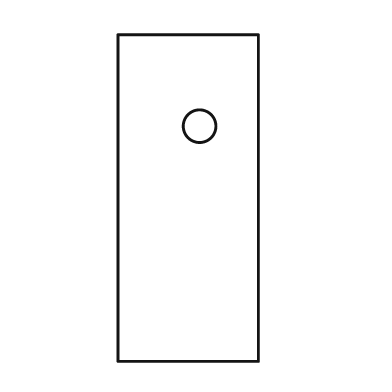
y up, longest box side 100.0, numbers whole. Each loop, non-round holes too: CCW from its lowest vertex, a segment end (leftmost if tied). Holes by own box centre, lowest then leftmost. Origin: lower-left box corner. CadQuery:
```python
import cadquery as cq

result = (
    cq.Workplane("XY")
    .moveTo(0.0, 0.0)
    .lineTo(43.0, 0.0)
    .lineTo(43.0, 100.0)
    .lineTo(0.0, 100.0)
    .close()
    .moveTo(25.0, 72.0)
    .circle(5.0)
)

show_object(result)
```